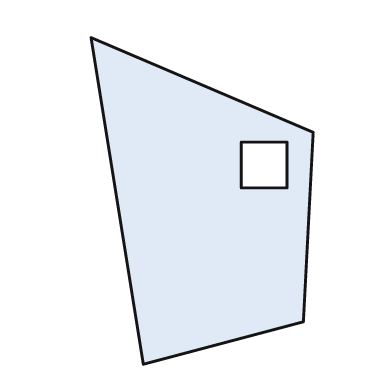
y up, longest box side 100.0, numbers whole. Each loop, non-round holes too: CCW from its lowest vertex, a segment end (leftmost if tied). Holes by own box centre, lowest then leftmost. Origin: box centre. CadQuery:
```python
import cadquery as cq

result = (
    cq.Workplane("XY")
    .moveTo(-18.0, -50.0)
    .lineTo(31.0, -37.0)
    .lineTo(34.0, 21.0)
    .lineTo(-34.0, 50.0)
    .close()
    .moveTo(12.0, 4.0)
    .lineTo(26.0, 4.0)
    .lineTo(26.0, 18.0)
    .lineTo(12.0, 18.0)
    .close()
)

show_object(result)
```